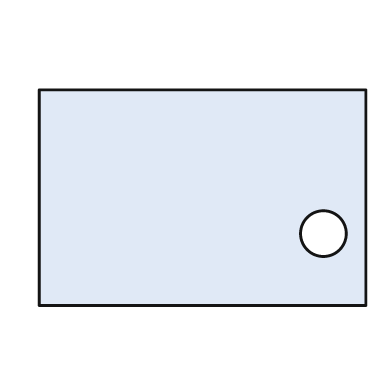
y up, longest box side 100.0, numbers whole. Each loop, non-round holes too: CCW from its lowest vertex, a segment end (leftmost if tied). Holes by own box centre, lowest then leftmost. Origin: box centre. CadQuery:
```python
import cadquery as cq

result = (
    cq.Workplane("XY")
    .moveTo(-50.0, -33.0)
    .lineTo(50.0, -33.0)
    .lineTo(50.0, 33.0)
    .lineTo(-50.0, 33.0)
    .close()
    .moveTo(37.0, -11.0)
    .circle(7.0)
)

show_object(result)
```